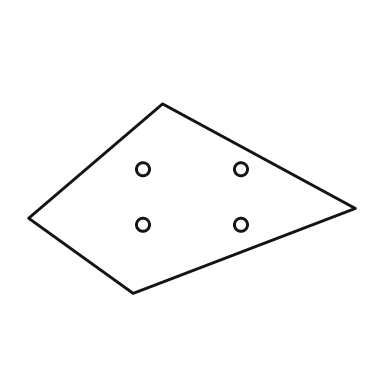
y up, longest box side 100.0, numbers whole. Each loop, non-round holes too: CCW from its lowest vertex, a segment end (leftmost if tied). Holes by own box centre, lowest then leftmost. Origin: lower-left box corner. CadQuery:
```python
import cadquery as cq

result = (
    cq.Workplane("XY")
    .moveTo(32.0, 0.0)
    .lineTo(100.0, 26.0)
    .lineTo(41.0, 58.0)
    .lineTo(0.0, 23.0)
    .close()
    .moveTo(35.0, 21.0)
    .circle(2.0)
    .moveTo(65.0, 21.0)
    .circle(2.0)
    .moveTo(35.0, 38.0)
    .circle(2.0)
    .moveTo(65.0, 38.0)
    .circle(2.0)
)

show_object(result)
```